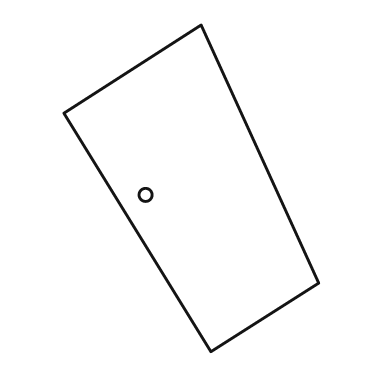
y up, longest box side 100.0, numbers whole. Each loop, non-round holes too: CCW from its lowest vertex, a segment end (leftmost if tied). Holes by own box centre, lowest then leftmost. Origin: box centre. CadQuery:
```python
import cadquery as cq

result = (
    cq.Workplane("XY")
    .moveTo(6.0, -50.0)
    .lineTo(39.0, -29.0)
    .lineTo(3.0, 50.0)
    .lineTo(-39.0, 23.0)
    .close()
    .moveTo(-14.0, -2.0)
    .circle(2.0)
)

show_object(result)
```